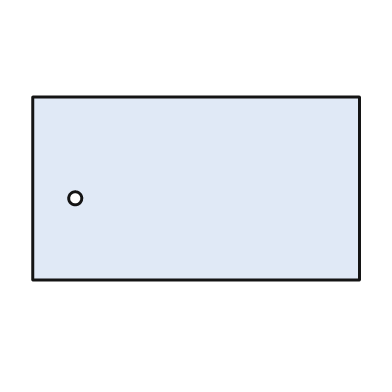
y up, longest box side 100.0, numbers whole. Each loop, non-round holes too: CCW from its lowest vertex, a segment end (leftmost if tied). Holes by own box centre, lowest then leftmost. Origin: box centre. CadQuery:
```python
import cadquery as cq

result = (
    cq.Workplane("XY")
    .moveTo(-50.0, -28.0)
    .lineTo(50.0, -28.0)
    .lineTo(50.0, 28.0)
    .lineTo(-50.0, 28.0)
    .close()
    .moveTo(-37.0, -3.0)
    .circle(2.0)
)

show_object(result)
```